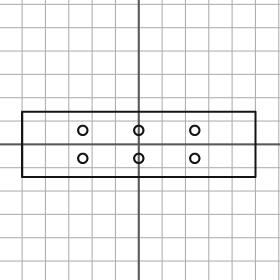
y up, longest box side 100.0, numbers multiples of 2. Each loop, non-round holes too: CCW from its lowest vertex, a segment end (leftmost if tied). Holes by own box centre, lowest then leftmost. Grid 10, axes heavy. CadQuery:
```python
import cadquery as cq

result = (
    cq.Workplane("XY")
    .moveTo(-50.0, -14.0)
    .lineTo(50.0, -14.0)
    .lineTo(50.0, 14.0)
    .lineTo(-50.0, 14.0)
    .close()
    .moveTo(-24.0, -6.0)
    .circle(2.0)
    .moveTo(0.0, -6.0)
    .circle(2.0)
    .moveTo(24.0, -6.0)
    .circle(2.0)
    .moveTo(-24.0, 6.0)
    .circle(2.0)
    .moveTo(0.0, 6.0)
    .circle(2.0)
    .moveTo(24.0, 6.0)
    .circle(2.0)
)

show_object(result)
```